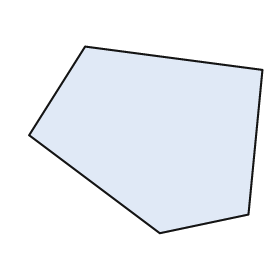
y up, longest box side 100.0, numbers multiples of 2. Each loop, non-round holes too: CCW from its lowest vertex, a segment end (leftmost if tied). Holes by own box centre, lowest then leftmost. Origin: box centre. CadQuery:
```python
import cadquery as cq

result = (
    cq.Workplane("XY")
    .moveTo(6.0, -40.0)
    .lineTo(44.0, -32.0)
    .lineTo(50.0, 30.0)
    .lineTo(-26.0, 40.0)
    .lineTo(-50.0, 2.0)
    .close()
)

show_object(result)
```